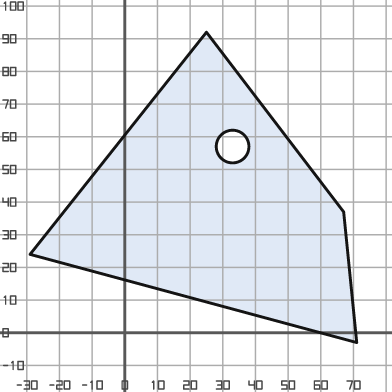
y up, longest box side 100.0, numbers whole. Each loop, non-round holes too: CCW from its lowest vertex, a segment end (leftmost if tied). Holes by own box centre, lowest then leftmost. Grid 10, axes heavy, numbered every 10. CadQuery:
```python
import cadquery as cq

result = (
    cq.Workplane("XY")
    .moveTo(71.0, -3.0)
    .lineTo(67.0, 37.0)
    .lineTo(25.0, 92.0)
    .lineTo(-29.0, 24.0)
    .close()
    .moveTo(33.0, 57.0)
    .circle(5.0)
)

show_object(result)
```